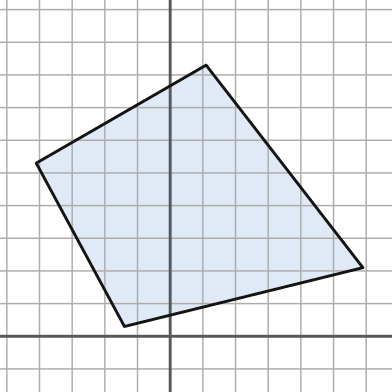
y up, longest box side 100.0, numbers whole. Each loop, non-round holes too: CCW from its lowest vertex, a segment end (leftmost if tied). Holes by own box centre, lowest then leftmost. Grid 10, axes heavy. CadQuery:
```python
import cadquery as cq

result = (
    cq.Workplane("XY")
    .moveTo(-14.0, 3.0)
    .lineTo(59.0, 21.0)
    .lineTo(11.0, 83.0)
    .lineTo(-41.0, 53.0)
    .close()
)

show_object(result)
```